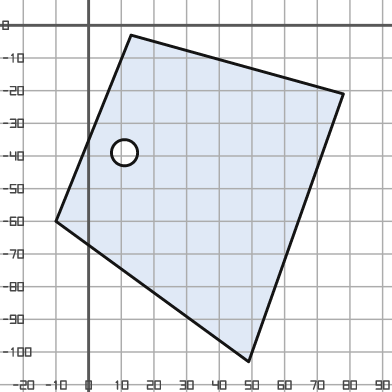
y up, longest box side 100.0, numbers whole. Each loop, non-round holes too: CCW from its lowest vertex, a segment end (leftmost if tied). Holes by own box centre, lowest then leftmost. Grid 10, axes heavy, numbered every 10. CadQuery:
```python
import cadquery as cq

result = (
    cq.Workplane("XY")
    .moveTo(49.0, -103.0)
    .lineTo(78.0, -21.0)
    .lineTo(13.0, -3.0)
    .lineTo(-10.0, -60.0)
    .close()
    .moveTo(11.0, -39.0)
    .circle(4.0)
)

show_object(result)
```